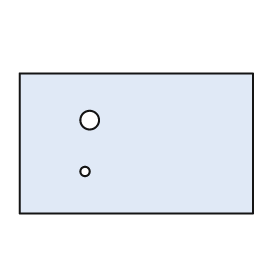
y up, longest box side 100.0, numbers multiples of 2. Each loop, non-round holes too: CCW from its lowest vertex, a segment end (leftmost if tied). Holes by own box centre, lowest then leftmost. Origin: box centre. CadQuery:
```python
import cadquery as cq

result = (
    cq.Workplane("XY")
    .moveTo(-50.0, -30.0)
    .lineTo(50.0, -30.0)
    .lineTo(50.0, 30.0)
    .lineTo(-50.0, 30.0)
    .close()
    .moveTo(-22.0, -12.0)
    .circle(2.0)
    .moveTo(-20.0, 10.0)
    .circle(4.0)
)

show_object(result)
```